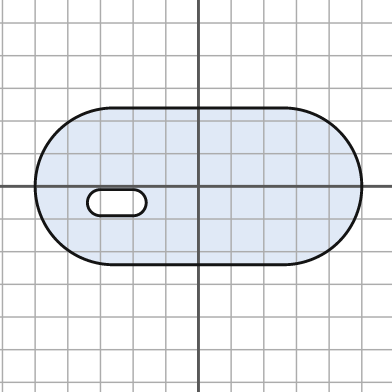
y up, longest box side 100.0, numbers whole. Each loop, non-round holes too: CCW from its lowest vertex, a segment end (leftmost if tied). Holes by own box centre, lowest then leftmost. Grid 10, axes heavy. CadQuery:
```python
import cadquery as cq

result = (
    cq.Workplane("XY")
    .moveTo(-26.0, -24.0)
    .lineTo(26.0, -24.0)
    .threePointArc((50.0, 0.0), (26.0, 24.0))
    .lineTo(-26.0, 24.0)
    .threePointArc((-50.0, 0.0), (-26.0, -24.0))
    .close()
    .moveTo(-30.0, -9.0)
    .lineTo(-20.0, -9.0)
    .threePointArc((-16.0, -5.0), (-20.0, -1.0))
    .lineTo(-30.0, -1.0)
    .threePointArc((-34.0, -5.0), (-30.0, -9.0))
    .close()
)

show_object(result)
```